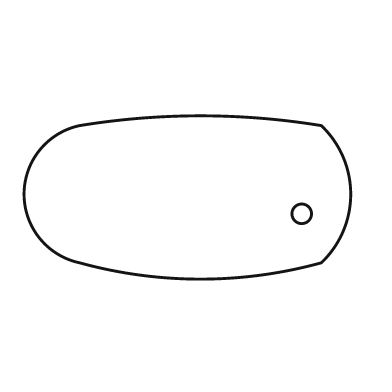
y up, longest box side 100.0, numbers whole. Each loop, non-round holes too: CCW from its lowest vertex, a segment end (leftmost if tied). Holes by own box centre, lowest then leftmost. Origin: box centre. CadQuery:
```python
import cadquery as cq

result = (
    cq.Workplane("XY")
    .moveTo(-33.0, -20.0)
    .threePointArc((4.0, -25.0), (41.0, -20.0))
    .threePointArc((50.0, 1.0), (41.0, 22.0))
    .threePointArc((4.0, 25.0), (-33.0, 22.0))
    .threePointArc((-50.0, 1.0), (-33.0, -20.0))
    .close()
    .moveTo(35.0, -5.0)
    .circle(3.0)
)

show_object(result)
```